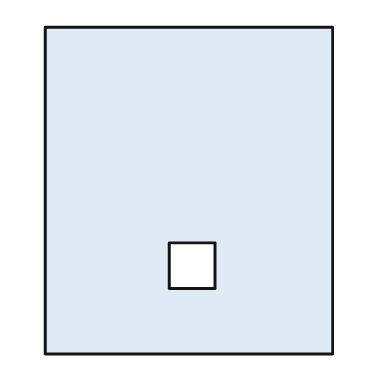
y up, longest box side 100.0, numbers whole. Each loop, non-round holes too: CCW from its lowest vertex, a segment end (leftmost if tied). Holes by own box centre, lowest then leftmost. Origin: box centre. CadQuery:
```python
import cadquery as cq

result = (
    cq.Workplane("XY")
    .moveTo(-44.0, -50.0)
    .lineTo(44.0, -50.0)
    .lineTo(44.0, 50.0)
    .lineTo(-44.0, 50.0)
    .close()
    .moveTo(-6.0, -30.0)
    .lineTo(8.0, -30.0)
    .lineTo(8.0, -16.0)
    .lineTo(-6.0, -16.0)
    .close()
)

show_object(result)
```